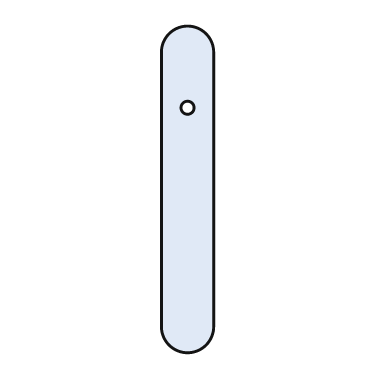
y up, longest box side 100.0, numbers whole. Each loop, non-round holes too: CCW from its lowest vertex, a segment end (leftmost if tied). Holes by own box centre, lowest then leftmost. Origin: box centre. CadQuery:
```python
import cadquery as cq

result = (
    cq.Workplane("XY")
    .moveTo(-8.0, -42.0)
    .threePointArc((0.0, -50.0), (8.0, -42.0))
    .lineTo(8.0, 42.0)
    .threePointArc((0.0, 50.0), (-8.0, 42.0))
    .close()
    .moveTo(0.0, 25.0)
    .circle(2.0)
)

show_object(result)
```